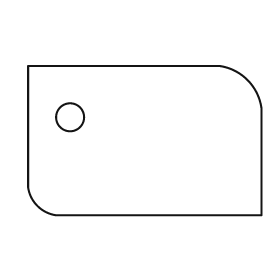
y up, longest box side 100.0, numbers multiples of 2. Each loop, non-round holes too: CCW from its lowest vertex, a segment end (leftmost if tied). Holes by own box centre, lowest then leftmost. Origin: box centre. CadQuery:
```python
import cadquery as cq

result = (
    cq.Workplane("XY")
    .moveTo(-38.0, -32.0)
    .lineTo(50.0, -32.0)
    .lineTo(50.0, 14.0)
    .threePointArc((44.0, 26.0), (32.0, 32.0))
    .lineTo(-50.0, 32.0)
    .lineTo(-50.0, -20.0)
    .threePointArc((-46.0, -28.0), (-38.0, -32.0))
    .close()
    .moveTo(-32.0, 10.0)
    .circle(6.0)
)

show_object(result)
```